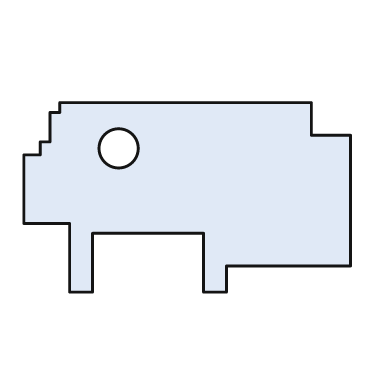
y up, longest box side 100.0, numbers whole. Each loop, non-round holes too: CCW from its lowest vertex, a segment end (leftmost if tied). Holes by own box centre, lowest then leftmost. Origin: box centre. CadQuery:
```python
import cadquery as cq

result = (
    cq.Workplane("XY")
    .moveTo(-36.0, -29.0)
    .lineTo(-29.0, -29.0)
    .lineTo(-29.0, -11.0)
    .lineTo(5.0, -11.0)
    .lineTo(5.0, -29.0)
    .lineTo(12.0, -29.0)
    .lineTo(12.0, -21.0)
    .lineTo(50.0, -21.0)
    .lineTo(50.0, 19.0)
    .lineTo(38.0, 19.0)
    .lineTo(38.0, 29.0)
    .lineTo(-39.0, 29.0)
    .lineTo(-39.0, 26.0)
    .lineTo(-42.0, 26.0)
    .lineTo(-42.0, 17.0)
    .lineTo(-45.0, 17.0)
    .lineTo(-45.0, 13.0)
    .lineTo(-50.0, 13.0)
    .lineTo(-50.0, -8.0)
    .lineTo(-36.0, -8.0)
    .close()
    .moveTo(-21.0, 15.0)
    .circle(6.0)
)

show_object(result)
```